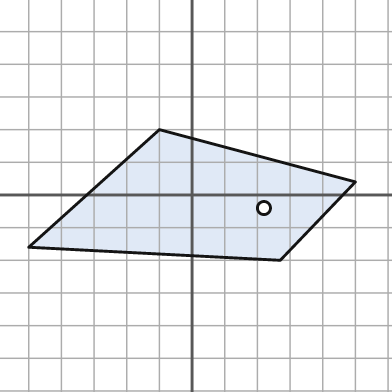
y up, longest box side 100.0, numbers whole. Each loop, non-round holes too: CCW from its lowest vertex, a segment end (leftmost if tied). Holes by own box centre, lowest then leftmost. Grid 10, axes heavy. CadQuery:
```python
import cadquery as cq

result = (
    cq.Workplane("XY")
    .moveTo(27.0, -20.0)
    .lineTo(50.0, 4.0)
    .lineTo(-10.0, 20.0)
    .lineTo(-50.0, -16.0)
    .close()
    .moveTo(22.0, -4.0)
    .circle(2.0)
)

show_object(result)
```